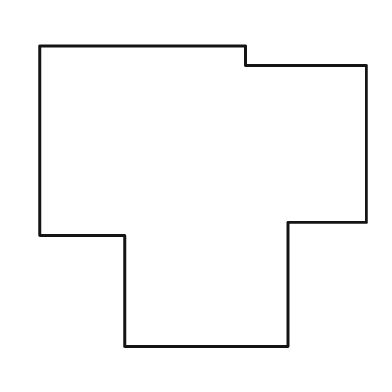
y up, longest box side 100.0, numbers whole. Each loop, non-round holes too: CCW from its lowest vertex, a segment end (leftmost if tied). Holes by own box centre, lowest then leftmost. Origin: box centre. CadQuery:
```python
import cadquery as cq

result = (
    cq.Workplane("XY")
    .moveTo(-24.0, -46.0)
    .lineTo(26.0, -46.0)
    .lineTo(26.0, -8.0)
    .lineTo(50.0, -8.0)
    .lineTo(50.0, 40.0)
    .lineTo(13.0, 40.0)
    .lineTo(13.0, 46.0)
    .lineTo(-50.0, 46.0)
    .lineTo(-50.0, -12.0)
    .lineTo(-24.0, -12.0)
    .close()
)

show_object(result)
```